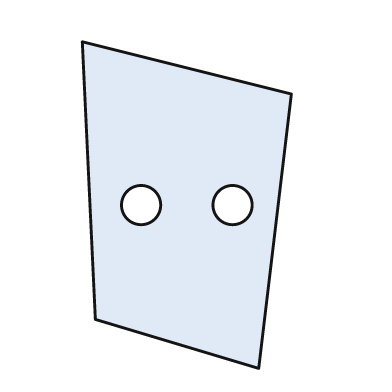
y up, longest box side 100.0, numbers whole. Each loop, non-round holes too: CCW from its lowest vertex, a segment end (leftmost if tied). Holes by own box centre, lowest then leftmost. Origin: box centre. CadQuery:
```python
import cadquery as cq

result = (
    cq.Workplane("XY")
    .moveTo(22.0, -50.0)
    .lineTo(32.0, 34.0)
    .lineTo(-32.0, 50.0)
    .lineTo(-28.0, -35.0)
    .close()
    .moveTo(-14.0, 0.0)
    .circle(6.0)
    .moveTo(14.0, 0.0)
    .circle(6.0)
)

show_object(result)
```